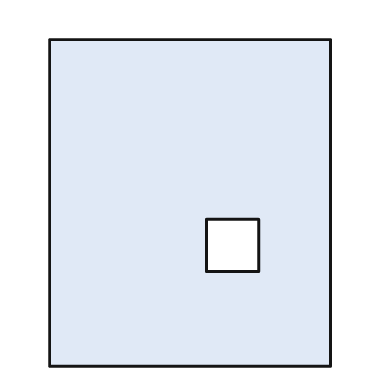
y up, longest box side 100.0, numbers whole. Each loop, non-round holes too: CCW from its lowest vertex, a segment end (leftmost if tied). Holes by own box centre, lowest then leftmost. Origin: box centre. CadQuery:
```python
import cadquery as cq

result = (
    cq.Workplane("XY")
    .moveTo(-43.0, -50.0)
    .lineTo(43.0, -50.0)
    .lineTo(43.0, 50.0)
    .lineTo(-43.0, 50.0)
    .close()
    .moveTo(5.0, -21.0)
    .lineTo(21.0, -21.0)
    .lineTo(21.0, -5.0)
    .lineTo(5.0, -5.0)
    .close()
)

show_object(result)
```